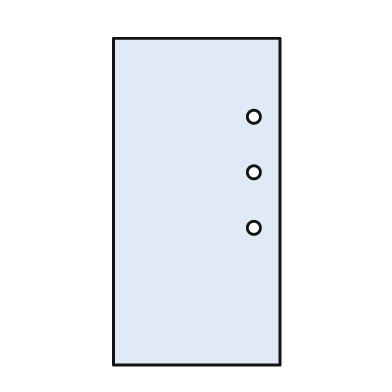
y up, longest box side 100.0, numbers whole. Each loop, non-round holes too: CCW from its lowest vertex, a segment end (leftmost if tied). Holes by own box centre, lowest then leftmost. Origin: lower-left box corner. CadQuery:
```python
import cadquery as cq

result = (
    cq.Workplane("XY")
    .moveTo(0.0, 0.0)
    .lineTo(51.0, 0.0)
    .lineTo(51.0, 100.0)
    .lineTo(0.0, 100.0)
    .close()
    .moveTo(43.0, 42.0)
    .circle(2.0)
    .moveTo(43.0, 59.0)
    .circle(2.0)
    .moveTo(43.0, 76.0)
    .circle(2.0)
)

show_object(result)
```